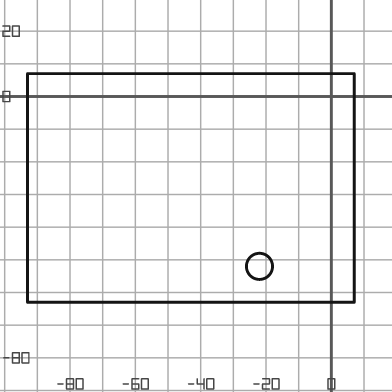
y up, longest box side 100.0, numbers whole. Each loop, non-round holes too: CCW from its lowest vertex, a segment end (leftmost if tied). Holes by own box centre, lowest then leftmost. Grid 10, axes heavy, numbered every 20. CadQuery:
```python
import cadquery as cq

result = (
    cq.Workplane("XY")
    .moveTo(-93.0, -63.0)
    .lineTo(7.0, -63.0)
    .lineTo(7.0, 7.0)
    .lineTo(-93.0, 7.0)
    .close()
    .moveTo(-22.0, -52.0)
    .circle(4.0)
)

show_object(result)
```